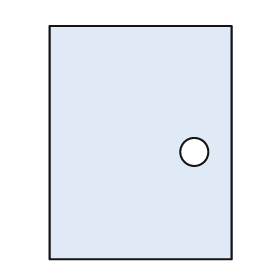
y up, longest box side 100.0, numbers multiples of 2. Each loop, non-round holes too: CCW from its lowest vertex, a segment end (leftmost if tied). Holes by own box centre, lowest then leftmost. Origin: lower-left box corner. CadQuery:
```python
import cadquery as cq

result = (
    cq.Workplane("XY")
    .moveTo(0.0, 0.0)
    .lineTo(78.0, 0.0)
    .lineTo(78.0, 100.0)
    .lineTo(0.0, 100.0)
    .close()
    .moveTo(62.0, 46.0)
    .circle(6.0)
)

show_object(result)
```